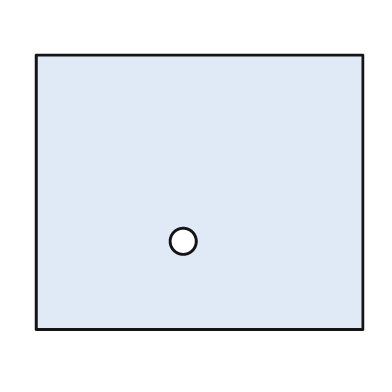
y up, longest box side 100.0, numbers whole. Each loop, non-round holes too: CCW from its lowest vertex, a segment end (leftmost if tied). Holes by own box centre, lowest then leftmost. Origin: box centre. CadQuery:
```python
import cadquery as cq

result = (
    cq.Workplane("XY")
    .moveTo(-50.0, -42.0)
    .lineTo(50.0, -42.0)
    .lineTo(50.0, 42.0)
    .lineTo(-50.0, 42.0)
    .close()
    .moveTo(-5.0, -15.0)
    .circle(4.0)
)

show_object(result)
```